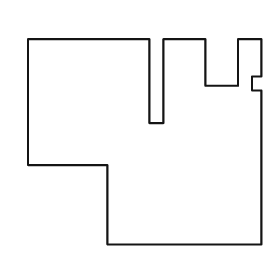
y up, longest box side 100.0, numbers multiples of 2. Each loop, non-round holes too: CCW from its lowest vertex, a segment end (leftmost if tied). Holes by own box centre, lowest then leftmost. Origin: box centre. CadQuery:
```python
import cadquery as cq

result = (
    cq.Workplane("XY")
    .moveTo(-16.0, -44.0)
    .lineTo(50.0, -44.0)
    .lineTo(50.0, 22.0)
    .lineTo(46.0, 22.0)
    .lineTo(46.0, 28.0)
    .lineTo(50.0, 28.0)
    .lineTo(50.0, 44.0)
    .lineTo(40.0, 44.0)
    .lineTo(40.0, 24.0)
    .lineTo(26.0, 24.0)
    .lineTo(26.0, 44.0)
    .lineTo(8.0, 44.0)
    .lineTo(8.0, 8.0)
    .lineTo(2.0, 8.0)
    .lineTo(2.0, 44.0)
    .lineTo(-50.0, 44.0)
    .lineTo(-50.0, -10.0)
    .lineTo(-16.0, -10.0)
    .close()
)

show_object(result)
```